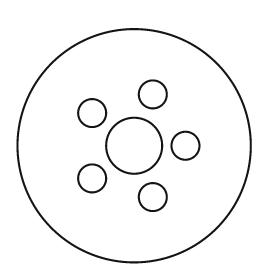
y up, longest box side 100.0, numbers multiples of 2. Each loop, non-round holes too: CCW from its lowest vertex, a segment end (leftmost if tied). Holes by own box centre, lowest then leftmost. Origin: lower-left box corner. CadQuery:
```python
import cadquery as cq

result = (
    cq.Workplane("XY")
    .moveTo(50.0, 50.0)
    .circle(50.0)
    .moveTo(58.0, 28.0)
    .circle(6.0)
    .moveTo(32.0, 36.0)
    .circle(6.0)
    .moveTo(50.0, 50.0)
    .circle(12.0)
    .moveTo(72.0, 50.0)
    .circle(6.0)
    .moveTo(32.0, 64.0)
    .circle(6.0)
    .moveTo(58.0, 72.0)
    .circle(6.0)
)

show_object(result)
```